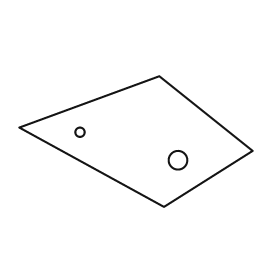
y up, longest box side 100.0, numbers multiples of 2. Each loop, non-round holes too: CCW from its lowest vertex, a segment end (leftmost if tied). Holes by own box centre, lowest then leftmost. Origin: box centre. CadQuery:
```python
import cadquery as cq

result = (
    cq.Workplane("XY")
    .moveTo(12.0, -28.0)
    .lineTo(50.0, -4.0)
    .lineTo(10.0, 28.0)
    .lineTo(-50.0, 6.0)
    .close()
    .moveTo(18.0, -8.0)
    .circle(4.0)
    .moveTo(-24.0, 4.0)
    .circle(2.0)
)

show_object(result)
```